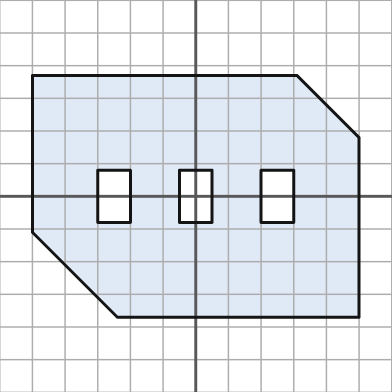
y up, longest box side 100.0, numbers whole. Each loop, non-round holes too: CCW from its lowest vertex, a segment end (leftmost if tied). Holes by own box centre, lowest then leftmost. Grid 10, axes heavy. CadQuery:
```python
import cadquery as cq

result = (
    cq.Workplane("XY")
    .moveTo(-24.0, -37.0)
    .lineTo(50.0, -37.0)
    .lineTo(50.0, 18.0)
    .lineTo(31.0, 37.0)
    .lineTo(-50.0, 37.0)
    .lineTo(-50.0, -11.0)
    .close()
    .moveTo(-30.0, -8.0)
    .lineTo(-20.0, -8.0)
    .lineTo(-20.0, 8.0)
    .lineTo(-30.0, 8.0)
    .close()
    .moveTo(-5.0, -8.0)
    .lineTo(5.0, -8.0)
    .lineTo(5.0, 8.0)
    .lineTo(-5.0, 8.0)
    .close()
    .moveTo(20.0, -8.0)
    .lineTo(30.0, -8.0)
    .lineTo(30.0, 8.0)
    .lineTo(20.0, 8.0)
    .close()
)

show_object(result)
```